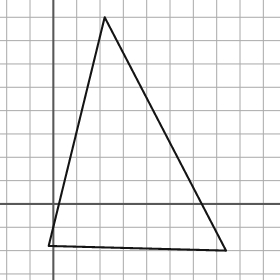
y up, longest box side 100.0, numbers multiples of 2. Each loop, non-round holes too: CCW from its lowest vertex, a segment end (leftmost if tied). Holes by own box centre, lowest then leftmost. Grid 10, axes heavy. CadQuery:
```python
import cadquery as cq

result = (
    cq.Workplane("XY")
    .moveTo(74.0, -20.0)
    .lineTo(22.0, 80.0)
    .lineTo(-2.0, -18.0)
    .close()
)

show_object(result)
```